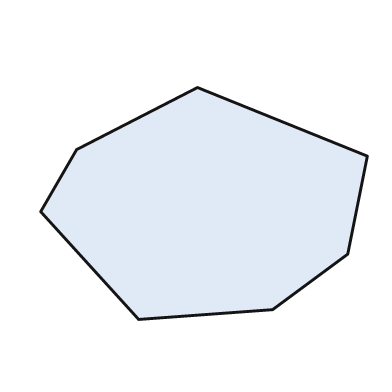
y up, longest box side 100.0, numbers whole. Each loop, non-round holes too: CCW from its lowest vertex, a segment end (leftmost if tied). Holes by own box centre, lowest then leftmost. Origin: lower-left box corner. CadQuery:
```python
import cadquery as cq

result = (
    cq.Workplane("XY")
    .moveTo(30.0, 0.0)
    .lineTo(71.0, 3.0)
    .lineTo(94.0, 20.0)
    .lineTo(100.0, 50.0)
    .lineTo(48.0, 71.0)
    .lineTo(11.0, 52.0)
    .lineTo(0.0, 33.0)
    .close()
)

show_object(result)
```